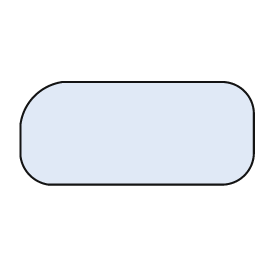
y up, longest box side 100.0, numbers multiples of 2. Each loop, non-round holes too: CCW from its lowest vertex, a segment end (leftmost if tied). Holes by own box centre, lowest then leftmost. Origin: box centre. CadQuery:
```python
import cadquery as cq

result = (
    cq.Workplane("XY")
    .moveTo(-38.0, -22.0)
    .lineTo(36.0, -22.0)
    .threePointArc((46.0, -18.0), (50.0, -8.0))
    .lineTo(50.0, 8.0)
    .threePointArc((46.0, 18.0), (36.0, 22.0))
    .lineTo(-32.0, 22.0)
    .threePointArc((-44.0, 16.0), (-50.0, 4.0))
    .lineTo(-50.0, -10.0)
    .threePointArc((-46.0, -18.0), (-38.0, -22.0))
    .close()
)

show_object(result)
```